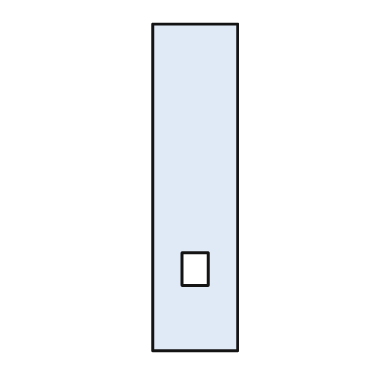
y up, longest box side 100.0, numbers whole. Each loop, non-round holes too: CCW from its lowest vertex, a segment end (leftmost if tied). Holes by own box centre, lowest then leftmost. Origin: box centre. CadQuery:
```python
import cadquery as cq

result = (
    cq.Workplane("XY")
    .moveTo(-13.0, -50.0)
    .lineTo(13.0, -50.0)
    .lineTo(13.0, 50.0)
    .lineTo(-13.0, 50.0)
    .close()
    .moveTo(-4.0, -30.0)
    .lineTo(4.0, -30.0)
    .lineTo(4.0, -20.0)
    .lineTo(-4.0, -20.0)
    .close()
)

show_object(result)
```